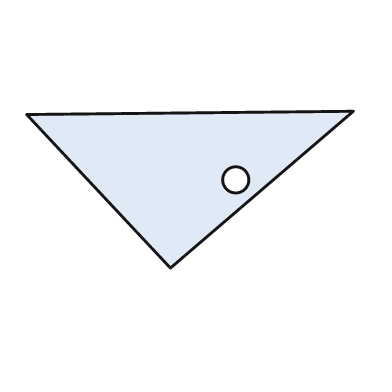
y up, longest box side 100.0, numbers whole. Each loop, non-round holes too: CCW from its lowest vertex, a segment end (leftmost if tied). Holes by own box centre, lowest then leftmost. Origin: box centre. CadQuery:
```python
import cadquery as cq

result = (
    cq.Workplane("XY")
    .moveTo(-6.0, -24.0)
    .lineTo(50.0, 24.0)
    .lineTo(-50.0, 23.0)
    .close()
    .moveTo(14.0, 3.0)
    .circle(4.0)
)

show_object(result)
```